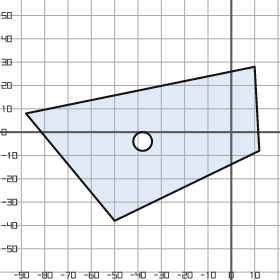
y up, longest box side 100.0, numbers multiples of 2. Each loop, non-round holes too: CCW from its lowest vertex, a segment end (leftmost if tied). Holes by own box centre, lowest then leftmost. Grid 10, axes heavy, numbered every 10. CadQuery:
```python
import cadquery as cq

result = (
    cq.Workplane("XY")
    .moveTo(-50.0, -38.0)
    .lineTo(12.0, -8.0)
    .lineTo(10.0, 28.0)
    .lineTo(-88.0, 8.0)
    .close()
    .moveTo(-38.0, -4.0)
    .circle(4.0)
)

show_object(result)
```